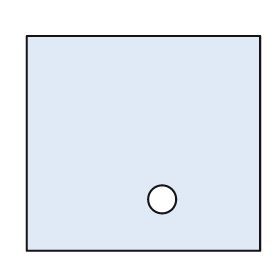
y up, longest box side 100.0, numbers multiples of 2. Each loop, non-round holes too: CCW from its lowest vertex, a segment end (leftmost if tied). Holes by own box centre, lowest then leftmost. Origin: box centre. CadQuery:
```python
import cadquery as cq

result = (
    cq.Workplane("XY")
    .moveTo(-50.0, -46.0)
    .lineTo(50.0, -46.0)
    .lineTo(50.0, 46.0)
    .lineTo(-50.0, 46.0)
    .close()
    .moveTo(8.0, -24.0)
    .circle(6.0)
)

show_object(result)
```